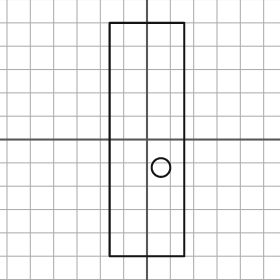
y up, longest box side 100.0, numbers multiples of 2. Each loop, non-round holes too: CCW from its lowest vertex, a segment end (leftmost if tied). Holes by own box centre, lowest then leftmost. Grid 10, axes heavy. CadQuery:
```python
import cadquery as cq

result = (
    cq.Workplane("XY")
    .moveTo(-16.0, -50.0)
    .lineTo(16.0, -50.0)
    .lineTo(16.0, 50.0)
    .lineTo(-16.0, 50.0)
    .close()
    .moveTo(6.0, -12.0)
    .circle(4.0)
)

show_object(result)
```